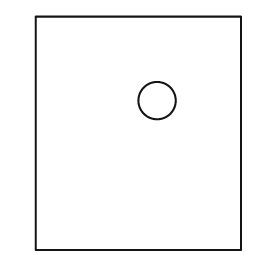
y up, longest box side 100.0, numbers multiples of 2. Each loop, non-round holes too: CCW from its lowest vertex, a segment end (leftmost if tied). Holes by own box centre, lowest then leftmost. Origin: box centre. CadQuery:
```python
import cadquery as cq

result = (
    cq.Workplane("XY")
    .moveTo(-44.0, -50.0)
    .lineTo(44.0, -50.0)
    .lineTo(44.0, 50.0)
    .lineTo(-44.0, 50.0)
    .close()
    .moveTo(8.0, 14.0)
    .circle(8.0)
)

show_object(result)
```